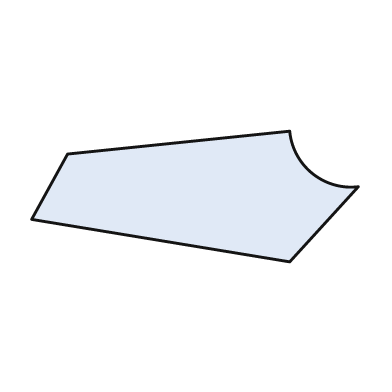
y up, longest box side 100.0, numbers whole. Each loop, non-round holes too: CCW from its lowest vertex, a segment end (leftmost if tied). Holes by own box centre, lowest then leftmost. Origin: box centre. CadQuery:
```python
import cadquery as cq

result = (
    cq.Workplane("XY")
    .moveTo(29.0, -20.0)
    .lineTo(50.0, 3.0)
    .threePointArc((36.0, 7.0), (29.0, 20.0))
    .lineTo(-39.0, 13.0)
    .lineTo(-50.0, -7.0)
    .close()
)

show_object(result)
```